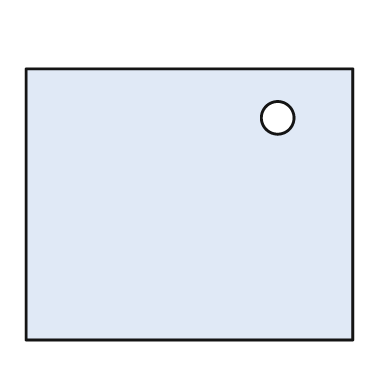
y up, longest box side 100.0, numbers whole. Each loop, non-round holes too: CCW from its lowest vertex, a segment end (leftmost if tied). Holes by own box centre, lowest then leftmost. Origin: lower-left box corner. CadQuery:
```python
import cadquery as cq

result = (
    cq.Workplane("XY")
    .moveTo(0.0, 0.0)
    .lineTo(100.0, 0.0)
    .lineTo(100.0, 83.0)
    .lineTo(0.0, 83.0)
    .close()
    .moveTo(77.0, 68.0)
    .circle(5.0)
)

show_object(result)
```